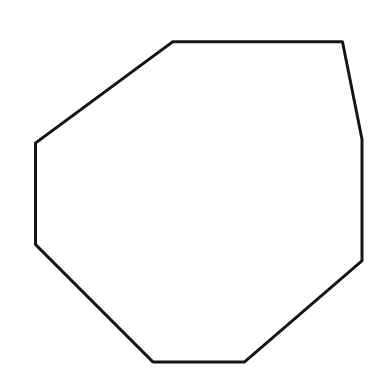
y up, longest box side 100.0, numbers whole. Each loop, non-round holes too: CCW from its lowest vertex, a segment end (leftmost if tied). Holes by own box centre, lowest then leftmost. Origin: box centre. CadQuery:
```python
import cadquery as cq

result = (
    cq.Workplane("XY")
    .moveTo(-14.0, -49.0)
    .lineTo(14.0, -49.0)
    .lineTo(50.0, -18.0)
    .lineTo(50.0, 19.0)
    .lineTo(44.0, 49.0)
    .lineTo(-8.0, 49.0)
    .lineTo(-50.0, 18.0)
    .lineTo(-50.0, -13.0)
    .close()
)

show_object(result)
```